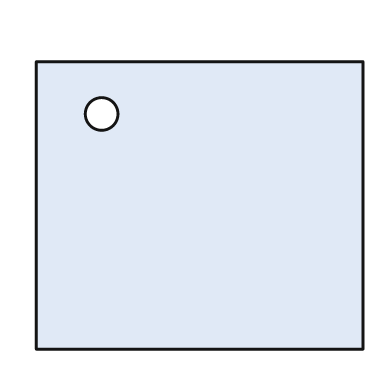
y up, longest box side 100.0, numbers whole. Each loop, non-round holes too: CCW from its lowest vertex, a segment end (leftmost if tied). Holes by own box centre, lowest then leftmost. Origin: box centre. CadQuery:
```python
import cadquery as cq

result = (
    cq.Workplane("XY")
    .moveTo(-50.0, -44.0)
    .lineTo(50.0, -44.0)
    .lineTo(50.0, 44.0)
    .lineTo(-50.0, 44.0)
    .close()
    .moveTo(-30.0, 28.0)
    .circle(5.0)
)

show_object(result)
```